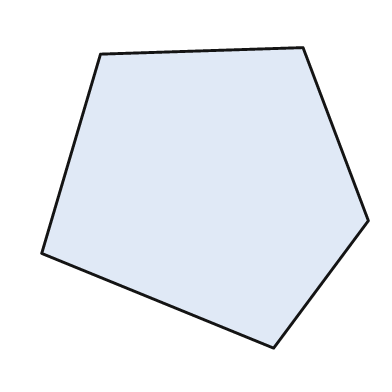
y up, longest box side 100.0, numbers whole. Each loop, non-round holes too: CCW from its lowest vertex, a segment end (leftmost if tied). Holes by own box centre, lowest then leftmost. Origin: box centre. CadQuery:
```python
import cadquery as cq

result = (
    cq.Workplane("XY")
    .moveTo(21.0, -46.0)
    .lineTo(50.0, -7.0)
    .lineTo(30.0, 46.0)
    .lineTo(-32.0, 44.0)
    .lineTo(-50.0, -17.0)
    .close()
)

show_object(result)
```